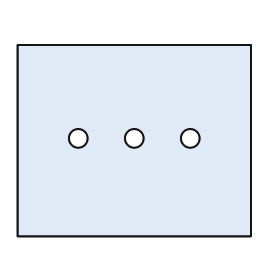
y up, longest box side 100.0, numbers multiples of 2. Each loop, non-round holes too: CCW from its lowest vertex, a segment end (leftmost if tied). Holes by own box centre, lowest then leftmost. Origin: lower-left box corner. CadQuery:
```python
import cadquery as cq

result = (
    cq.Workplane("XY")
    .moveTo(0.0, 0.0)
    .lineTo(100.0, 0.0)
    .lineTo(100.0, 82.0)
    .lineTo(0.0, 82.0)
    .close()
    .moveTo(26.0, 42.0)
    .circle(4.0)
    .moveTo(50.0, 42.0)
    .circle(4.0)
    .moveTo(74.0, 42.0)
    .circle(4.0)
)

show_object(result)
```